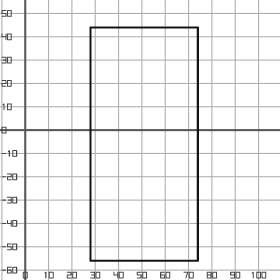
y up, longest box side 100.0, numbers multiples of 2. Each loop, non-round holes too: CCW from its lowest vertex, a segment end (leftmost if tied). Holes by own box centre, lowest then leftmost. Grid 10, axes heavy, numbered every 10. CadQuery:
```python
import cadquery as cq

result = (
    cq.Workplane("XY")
    .moveTo(28.0, -56.0)
    .lineTo(74.0, -56.0)
    .lineTo(74.0, 44.0)
    .lineTo(28.0, 44.0)
    .close()
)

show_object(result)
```